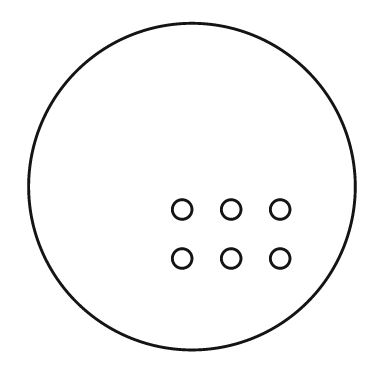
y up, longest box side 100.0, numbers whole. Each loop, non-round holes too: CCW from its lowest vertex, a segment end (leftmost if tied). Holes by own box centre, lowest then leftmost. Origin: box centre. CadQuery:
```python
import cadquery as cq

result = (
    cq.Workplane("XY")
    .moveTo(0.0, 0.0)
    .circle(50.0)
    .moveTo(-3.0, -22.0)
    .circle(3.0)
    .moveTo(12.0, -22.0)
    .circle(3.0)
    .moveTo(27.0, -22.0)
    .circle(3.0)
    .moveTo(-3.0, -7.0)
    .circle(3.0)
    .moveTo(12.0, -7.0)
    .circle(3.0)
    .moveTo(27.0, -7.0)
    .circle(3.0)
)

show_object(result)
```